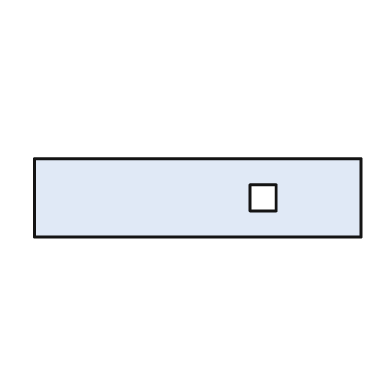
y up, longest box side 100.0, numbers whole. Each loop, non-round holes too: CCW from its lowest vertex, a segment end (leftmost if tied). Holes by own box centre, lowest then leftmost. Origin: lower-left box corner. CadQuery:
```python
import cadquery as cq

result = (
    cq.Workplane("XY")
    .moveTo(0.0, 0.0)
    .lineTo(100.0, 0.0)
    .lineTo(100.0, 24.0)
    .lineTo(0.0, 24.0)
    .close()
    .moveTo(66.0, 8.0)
    .lineTo(74.0, 8.0)
    .lineTo(74.0, 16.0)
    .lineTo(66.0, 16.0)
    .close()
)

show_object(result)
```